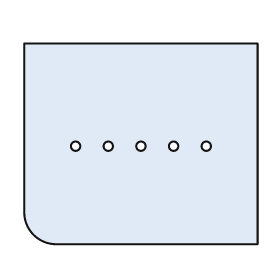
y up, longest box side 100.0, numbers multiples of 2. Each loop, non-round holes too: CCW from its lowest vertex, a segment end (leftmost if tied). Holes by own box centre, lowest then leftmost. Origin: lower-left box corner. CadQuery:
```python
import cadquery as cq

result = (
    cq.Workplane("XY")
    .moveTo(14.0, 0.0)
    .lineTo(100.0, 0.0)
    .lineTo(100.0, 86.0)
    .lineTo(0.0, 86.0)
    .lineTo(0.0, 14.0)
    .threePointArc((4.0, 4.0), (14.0, 0.0))
    .close()
    .moveTo(22.0, 42.0)
    .circle(2.0)
    .moveTo(36.0, 42.0)
    .circle(2.0)
    .moveTo(50.0, 42.0)
    .circle(2.0)
    .moveTo(64.0, 42.0)
    .circle(2.0)
    .moveTo(78.0, 42.0)
    .circle(2.0)
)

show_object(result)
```